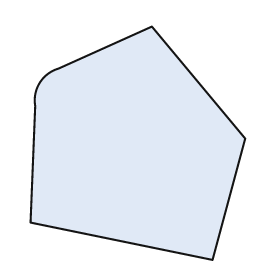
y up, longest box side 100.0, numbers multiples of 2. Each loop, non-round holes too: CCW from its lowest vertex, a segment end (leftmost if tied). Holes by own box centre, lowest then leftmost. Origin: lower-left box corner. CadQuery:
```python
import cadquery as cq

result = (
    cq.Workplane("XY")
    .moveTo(78.0, 0.0)
    .lineTo(92.0, 52.0)
    .lineTo(52.0, 100.0)
    .lineTo(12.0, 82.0)
    .threePointArc((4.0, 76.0), (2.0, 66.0))
    .lineTo(0.0, 16.0)
    .close()
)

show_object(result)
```